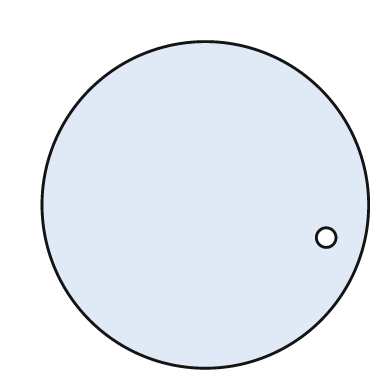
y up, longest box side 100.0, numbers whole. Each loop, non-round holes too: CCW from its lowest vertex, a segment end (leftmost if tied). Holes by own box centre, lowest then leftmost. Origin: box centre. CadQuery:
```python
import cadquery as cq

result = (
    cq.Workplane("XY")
    .moveTo(0.0, 0.0)
    .circle(50.0)
    .moveTo(37.0, -10.0)
    .circle(3.0)
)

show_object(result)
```